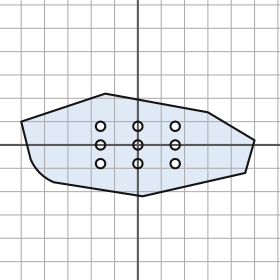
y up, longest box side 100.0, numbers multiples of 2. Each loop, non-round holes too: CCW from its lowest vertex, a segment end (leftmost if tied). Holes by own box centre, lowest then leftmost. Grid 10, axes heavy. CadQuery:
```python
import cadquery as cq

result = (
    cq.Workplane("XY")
    .moveTo(2.0, -22.0)
    .lineTo(46.0, -12.0)
    .lineTo(50.0, 2.0)
    .lineTo(30.0, 14.0)
    .lineTo(-14.0, 22.0)
    .lineTo(-50.0, 10.0)
    .lineTo(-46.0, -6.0)
    .threePointArc((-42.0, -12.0), (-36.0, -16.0))
    .close()
    .moveTo(-16.0, -8.0)
    .circle(2.0)
    .moveTo(0.0, -8.0)
    .circle(2.0)
    .moveTo(16.0, -8.0)
    .circle(2.0)
    .moveTo(-16.0, 0.0)
    .circle(2.0)
    .moveTo(0.0, 0.0)
    .circle(2.0)
    .moveTo(16.0, 0.0)
    .circle(2.0)
    .moveTo(-16.0, 8.0)
    .circle(2.0)
    .moveTo(0.0, 8.0)
    .circle(2.0)
    .moveTo(16.0, 8.0)
    .circle(2.0)
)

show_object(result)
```